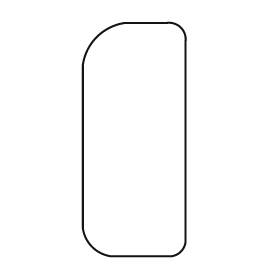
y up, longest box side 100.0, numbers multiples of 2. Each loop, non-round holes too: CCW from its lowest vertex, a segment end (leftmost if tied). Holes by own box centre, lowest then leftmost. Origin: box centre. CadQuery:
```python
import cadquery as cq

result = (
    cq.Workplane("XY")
    .moveTo(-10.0, -50.0)
    .lineTo(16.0, -50.0)
    .threePointArc((20.0, -48.0), (22.0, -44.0))
    .lineTo(22.0, 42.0)
    .threePointArc((20.0, 48.0), (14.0, 50.0))
    .lineTo(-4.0, 50.0)
    .threePointArc((-16.0, 44.0), (-22.0, 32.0))
    .lineTo(-22.0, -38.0)
    .threePointArc((-18.0, -46.0), (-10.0, -50.0))
    .close()
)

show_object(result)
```